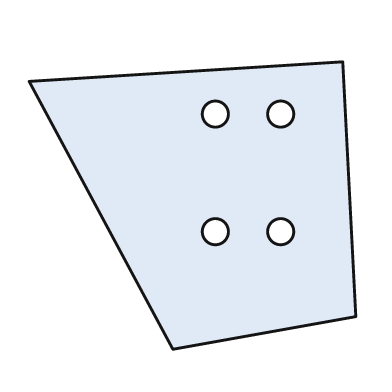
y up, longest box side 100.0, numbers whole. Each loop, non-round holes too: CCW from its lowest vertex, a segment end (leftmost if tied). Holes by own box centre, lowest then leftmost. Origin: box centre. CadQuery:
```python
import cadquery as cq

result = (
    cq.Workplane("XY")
    .moveTo(-6.0, -44.0)
    .lineTo(50.0, -34.0)
    .lineTo(46.0, 44.0)
    .lineTo(-50.0, 38.0)
    .close()
    .moveTo(7.0, -8.0)
    .circle(4.0)
    .moveTo(27.0, -8.0)
    .circle(4.0)
    .moveTo(7.0, 28.0)
    .circle(4.0)
    .moveTo(27.0, 28.0)
    .circle(4.0)
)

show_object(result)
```